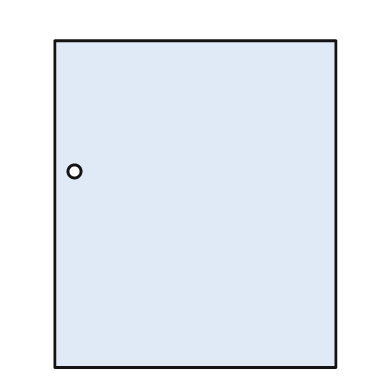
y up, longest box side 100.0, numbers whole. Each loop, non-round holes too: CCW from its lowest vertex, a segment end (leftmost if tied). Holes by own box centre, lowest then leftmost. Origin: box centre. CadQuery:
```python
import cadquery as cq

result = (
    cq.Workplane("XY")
    .moveTo(-43.0, -50.0)
    .lineTo(43.0, -50.0)
    .lineTo(43.0, 50.0)
    .lineTo(-43.0, 50.0)
    .close()
    .moveTo(-37.0, 10.0)
    .circle(2.0)
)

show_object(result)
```